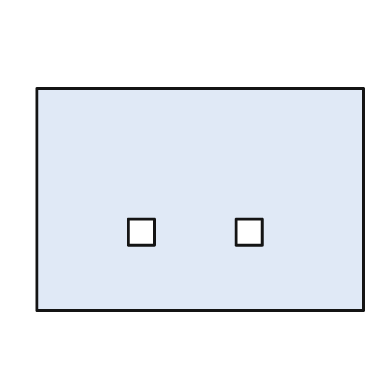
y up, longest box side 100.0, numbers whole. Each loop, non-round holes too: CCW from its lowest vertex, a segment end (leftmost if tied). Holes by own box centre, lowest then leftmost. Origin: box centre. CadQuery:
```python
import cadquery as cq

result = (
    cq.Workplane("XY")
    .moveTo(-50.0, -34.0)
    .lineTo(50.0, -34.0)
    .lineTo(50.0, 34.0)
    .lineTo(-50.0, 34.0)
    .close()
    .moveTo(-22.0, -14.0)
    .lineTo(-14.0, -14.0)
    .lineTo(-14.0, -6.0)
    .lineTo(-22.0, -6.0)
    .close()
    .moveTo(11.0, -14.0)
    .lineTo(19.0, -14.0)
    .lineTo(19.0, -6.0)
    .lineTo(11.0, -6.0)
    .close()
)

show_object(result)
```